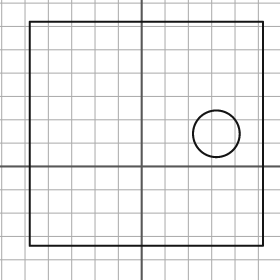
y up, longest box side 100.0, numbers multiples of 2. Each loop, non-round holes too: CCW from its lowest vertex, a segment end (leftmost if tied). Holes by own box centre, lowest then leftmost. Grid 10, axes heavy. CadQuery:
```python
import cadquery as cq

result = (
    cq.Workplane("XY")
    .moveTo(-48.0, -34.0)
    .lineTo(52.0, -34.0)
    .lineTo(52.0, 62.0)
    .lineTo(-48.0, 62.0)
    .close()
    .moveTo(32.0, 14.0)
    .circle(10.0)
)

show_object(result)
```